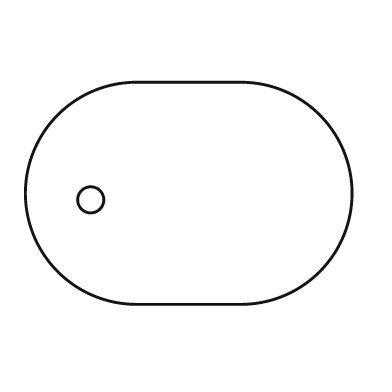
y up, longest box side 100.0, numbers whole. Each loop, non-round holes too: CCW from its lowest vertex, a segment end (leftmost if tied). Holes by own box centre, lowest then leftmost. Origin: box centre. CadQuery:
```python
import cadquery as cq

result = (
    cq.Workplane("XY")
    .moveTo(-16.0, -34.0)
    .lineTo(16.0, -34.0)
    .threePointArc((50.0, 0.0), (16.0, 34.0))
    .lineTo(-16.0, 34.0)
    .threePointArc((-50.0, 0.0), (-16.0, -34.0))
    .close()
    .moveTo(-30.0, -2.0)
    .circle(4.0)
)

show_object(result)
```